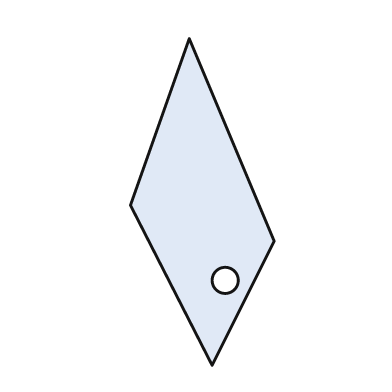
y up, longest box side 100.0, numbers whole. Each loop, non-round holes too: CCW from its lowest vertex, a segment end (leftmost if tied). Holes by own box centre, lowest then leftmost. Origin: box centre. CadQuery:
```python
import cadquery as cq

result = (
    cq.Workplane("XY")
    .moveTo(3.0, -50.0)
    .lineTo(22.0, -12.0)
    .lineTo(-4.0, 50.0)
    .lineTo(-22.0, -1.0)
    .close()
    .moveTo(7.0, -24.0)
    .circle(4.0)
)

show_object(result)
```